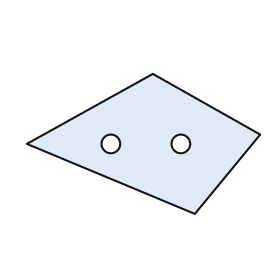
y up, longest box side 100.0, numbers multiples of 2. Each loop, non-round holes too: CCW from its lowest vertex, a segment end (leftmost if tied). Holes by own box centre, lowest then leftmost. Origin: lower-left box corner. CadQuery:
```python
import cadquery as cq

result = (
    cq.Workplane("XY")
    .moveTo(72.0, 0.0)
    .lineTo(100.0, 34.0)
    .lineTo(54.0, 60.0)
    .lineTo(0.0, 30.0)
    .close()
    .moveTo(36.0, 30.0)
    .circle(4.0)
    .moveTo(66.0, 30.0)
    .circle(4.0)
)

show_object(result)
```